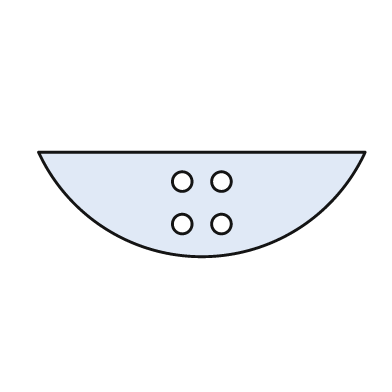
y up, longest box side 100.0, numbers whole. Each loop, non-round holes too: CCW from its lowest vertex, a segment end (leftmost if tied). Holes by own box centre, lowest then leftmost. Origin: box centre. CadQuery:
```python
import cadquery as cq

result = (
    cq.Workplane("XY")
    .moveTo(-50.0, 16.0)
    .threePointArc((0.0, -16.0), (50.0, 16.0))
    .close()
    .moveTo(-6.0, -6.0)
    .circle(3.0)
    .moveTo(6.0, -6.0)
    .circle(3.0)
    .moveTo(-6.0, 7.0)
    .circle(3.0)
    .moveTo(6.0, 7.0)
    .circle(3.0)
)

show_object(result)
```